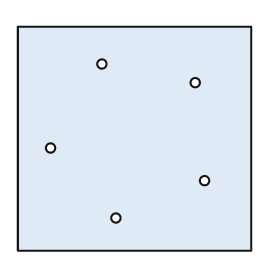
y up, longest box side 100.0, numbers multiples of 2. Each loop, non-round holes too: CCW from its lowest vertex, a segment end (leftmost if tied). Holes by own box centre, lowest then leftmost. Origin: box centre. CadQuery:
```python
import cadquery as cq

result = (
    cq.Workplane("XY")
    .moveTo(-50.0, -48.0)
    .lineTo(50.0, -48.0)
    .lineTo(50.0, 48.0)
    .lineTo(-50.0, 48.0)
    .close()
    .moveTo(-8.0, -34.0)
    .circle(2.0)
    .moveTo(30.0, -18.0)
    .circle(2.0)
    .moveTo(-36.0, -4.0)
    .circle(2.0)
    .moveTo(26.0, 24.0)
    .circle(2.0)
    .moveTo(-14.0, 32.0)
    .circle(2.0)
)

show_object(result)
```